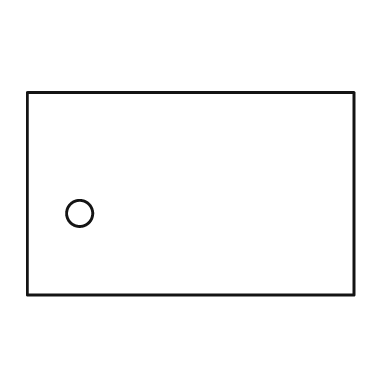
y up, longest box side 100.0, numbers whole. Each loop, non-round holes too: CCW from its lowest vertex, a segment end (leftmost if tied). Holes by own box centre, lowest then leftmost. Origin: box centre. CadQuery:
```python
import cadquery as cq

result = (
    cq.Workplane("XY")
    .moveTo(-50.0, -31.0)
    .lineTo(50.0, -31.0)
    .lineTo(50.0, 31.0)
    .lineTo(-50.0, 31.0)
    .close()
    .moveTo(-34.0, -6.0)
    .circle(4.0)
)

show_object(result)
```